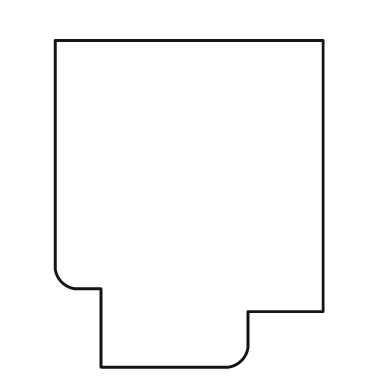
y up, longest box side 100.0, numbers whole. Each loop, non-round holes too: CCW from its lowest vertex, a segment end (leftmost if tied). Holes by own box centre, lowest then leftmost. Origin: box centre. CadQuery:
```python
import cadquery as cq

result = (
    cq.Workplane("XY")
    .moveTo(-27.0, -50.0)
    .lineTo(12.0, -50.0)
    .threePointArc((16.0, -48.0), (18.0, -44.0))
    .lineTo(18.0, -33.0)
    .lineTo(41.0, -33.0)
    .lineTo(41.0, 50.0)
    .lineTo(-41.0, 50.0)
    .lineTo(-41.0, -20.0)
    .threePointArc((-39.0, -24.0), (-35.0, -26.0))
    .lineTo(-27.0, -26.0)
    .close()
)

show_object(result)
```